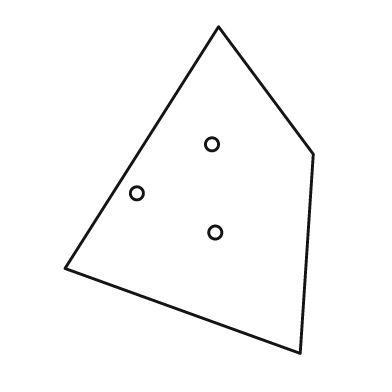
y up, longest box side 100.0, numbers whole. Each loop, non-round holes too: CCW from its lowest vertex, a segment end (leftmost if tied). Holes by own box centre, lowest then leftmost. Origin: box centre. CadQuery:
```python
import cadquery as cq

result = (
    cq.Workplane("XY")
    .moveTo(34.0, -50.0)
    .lineTo(38.0, 11.0)
    .lineTo(9.0, 50.0)
    .lineTo(-38.0, -24.0)
    .close()
    .moveTo(8.0, -13.0)
    .circle(2.0)
    .moveTo(-16.0, -1.0)
    .circle(2.0)
    .moveTo(7.0, 14.0)
    .circle(2.0)
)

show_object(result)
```